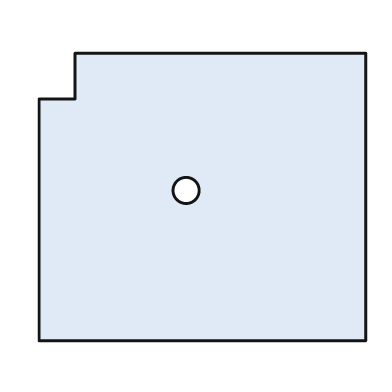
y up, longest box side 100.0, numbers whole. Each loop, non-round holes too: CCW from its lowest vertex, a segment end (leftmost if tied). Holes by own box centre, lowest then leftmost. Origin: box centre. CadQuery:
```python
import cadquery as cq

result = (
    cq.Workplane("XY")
    .moveTo(-50.0, -44.0)
    .lineTo(50.0, -44.0)
    .lineTo(50.0, 44.0)
    .lineTo(-39.0, 44.0)
    .lineTo(-39.0, 30.0)
    .lineTo(-50.0, 30.0)
    .close()
    .moveTo(-5.0, 2.0)
    .circle(4.0)
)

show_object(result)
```